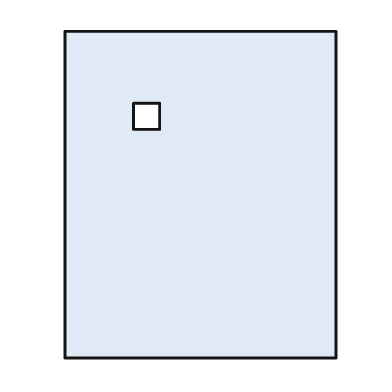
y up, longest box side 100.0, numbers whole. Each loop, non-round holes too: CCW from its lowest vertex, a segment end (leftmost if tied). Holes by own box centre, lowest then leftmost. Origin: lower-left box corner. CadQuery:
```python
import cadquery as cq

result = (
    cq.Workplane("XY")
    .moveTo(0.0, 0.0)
    .lineTo(83.0, 0.0)
    .lineTo(83.0, 100.0)
    .lineTo(0.0, 100.0)
    .close()
    .moveTo(21.0, 70.0)
    .lineTo(29.0, 70.0)
    .lineTo(29.0, 78.0)
    .lineTo(21.0, 78.0)
    .close()
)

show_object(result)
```